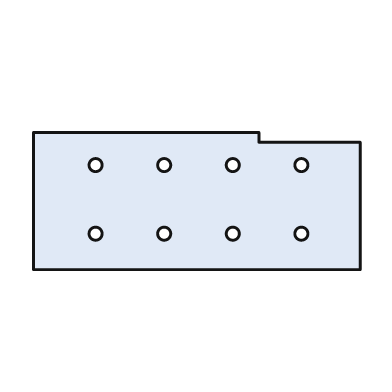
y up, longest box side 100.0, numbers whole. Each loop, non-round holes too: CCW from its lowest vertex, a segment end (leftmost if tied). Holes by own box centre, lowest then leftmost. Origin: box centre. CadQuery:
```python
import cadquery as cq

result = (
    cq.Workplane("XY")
    .moveTo(-50.0, -21.0)
    .lineTo(50.0, -21.0)
    .lineTo(50.0, 18.0)
    .lineTo(19.0, 18.0)
    .lineTo(19.0, 21.0)
    .lineTo(-50.0, 21.0)
    .close()
    .moveTo(-31.0, -10.0)
    .circle(2.0)
    .moveTo(-10.0, -10.0)
    .circle(2.0)
    .moveTo(11.0, -10.0)
    .circle(2.0)
    .moveTo(32.0, -10.0)
    .circle(2.0)
    .moveTo(-31.0, 11.0)
    .circle(2.0)
    .moveTo(-10.0, 11.0)
    .circle(2.0)
    .moveTo(11.0, 11.0)
    .circle(2.0)
    .moveTo(32.0, 11.0)
    .circle(2.0)
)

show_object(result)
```